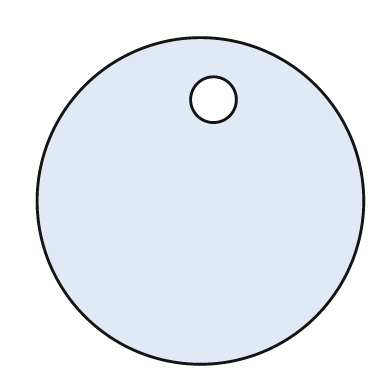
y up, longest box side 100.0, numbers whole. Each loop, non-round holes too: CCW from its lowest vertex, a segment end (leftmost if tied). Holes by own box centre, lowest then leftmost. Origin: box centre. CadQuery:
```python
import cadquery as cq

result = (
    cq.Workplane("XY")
    .moveTo(0.0, 0.0)
    .circle(50.0)
    .moveTo(4.0, 31.0)
    .circle(7.0)
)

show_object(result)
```